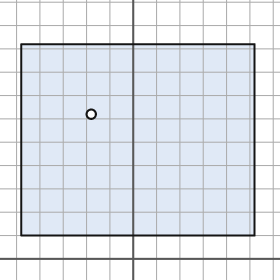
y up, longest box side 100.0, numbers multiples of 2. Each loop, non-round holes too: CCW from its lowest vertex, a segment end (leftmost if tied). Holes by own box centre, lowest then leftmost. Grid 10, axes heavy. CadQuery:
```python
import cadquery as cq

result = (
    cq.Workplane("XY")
    .moveTo(-48.0, 10.0)
    .lineTo(52.0, 10.0)
    .lineTo(52.0, 92.0)
    .lineTo(-48.0, 92.0)
    .close()
    .moveTo(-18.0, 62.0)
    .circle(2.0)
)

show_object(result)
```